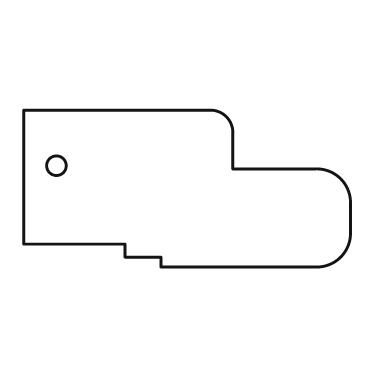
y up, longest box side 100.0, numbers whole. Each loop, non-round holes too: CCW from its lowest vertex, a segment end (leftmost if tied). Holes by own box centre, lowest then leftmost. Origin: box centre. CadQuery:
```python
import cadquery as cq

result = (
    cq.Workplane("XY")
    .moveTo(-8.0, -24.0)
    .lineTo(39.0, -24.0)
    .threePointArc((47.0, -21.0), (50.0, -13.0))
    .lineTo(50.0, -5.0)
    .threePointArc((47.0, 3.0), (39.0, 6.0))
    .lineTo(14.0, 6.0)
    .lineTo(14.0, 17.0)
    .threePointArc((12.0, 22.0), (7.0, 24.0))
    .lineTo(-50.0, 24.0)
    .lineTo(-50.0, -17.0)
    .lineTo(-19.0, -17.0)
    .lineTo(-19.0, -21.0)
    .lineTo(-8.0, -21.0)
    .close()
    .moveTo(-40.0, 7.0)
    .circle(3.0)
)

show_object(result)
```